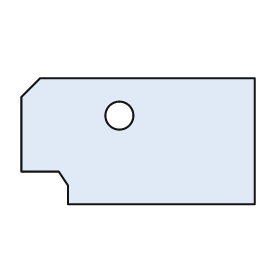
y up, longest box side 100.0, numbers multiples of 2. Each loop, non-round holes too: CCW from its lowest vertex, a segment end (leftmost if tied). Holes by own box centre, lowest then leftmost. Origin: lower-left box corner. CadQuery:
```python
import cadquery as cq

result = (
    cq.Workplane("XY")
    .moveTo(20.0, 0.0)
    .lineTo(100.0, 0.0)
    .lineTo(100.0, 54.0)
    .lineTo(8.0, 54.0)
    .lineTo(0.0, 46.0)
    .lineTo(0.0, 14.0)
    .lineTo(16.0, 14.0)
    .lineTo(20.0, 8.0)
    .close()
    .moveTo(42.0, 38.0)
    .circle(6.0)
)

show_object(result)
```